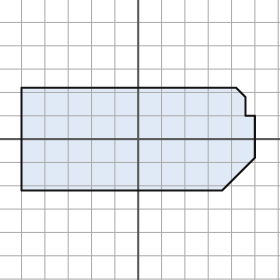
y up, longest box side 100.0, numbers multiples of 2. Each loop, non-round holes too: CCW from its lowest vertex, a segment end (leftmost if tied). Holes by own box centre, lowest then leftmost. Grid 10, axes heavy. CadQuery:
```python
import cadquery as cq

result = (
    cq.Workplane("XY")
    .moveTo(-50.0, -22.0)
    .lineTo(36.0, -22.0)
    .lineTo(50.0, -8.0)
    .lineTo(50.0, 10.0)
    .lineTo(46.0, 10.0)
    .lineTo(46.0, 18.0)
    .lineTo(42.0, 22.0)
    .lineTo(-50.0, 22.0)
    .close()
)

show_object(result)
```